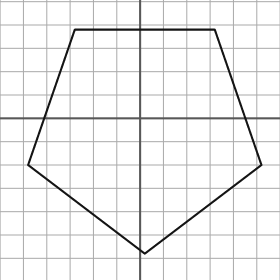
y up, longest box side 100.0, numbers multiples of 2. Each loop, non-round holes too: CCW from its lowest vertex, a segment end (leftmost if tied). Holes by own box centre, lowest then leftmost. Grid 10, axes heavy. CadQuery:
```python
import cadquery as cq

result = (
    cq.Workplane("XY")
    .moveTo(2.0, -58.0)
    .lineTo(52.0, -20.0)
    .lineTo(32.0, 38.0)
    .lineTo(-28.0, 38.0)
    .lineTo(-48.0, -20.0)
    .close()
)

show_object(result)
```